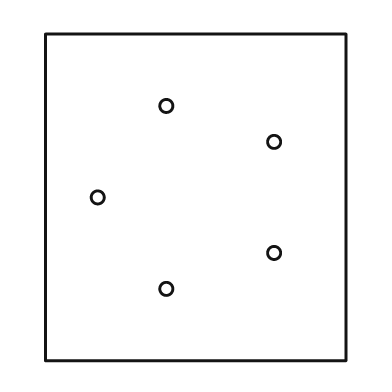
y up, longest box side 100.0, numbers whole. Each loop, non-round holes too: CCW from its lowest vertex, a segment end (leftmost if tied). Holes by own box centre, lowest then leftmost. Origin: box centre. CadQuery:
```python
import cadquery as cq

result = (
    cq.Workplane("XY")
    .moveTo(-46.0, -50.0)
    .lineTo(46.0, -50.0)
    .lineTo(46.0, 50.0)
    .lineTo(-46.0, 50.0)
    .close()
    .moveTo(-9.0, -28.0)
    .circle(2.0)
    .moveTo(24.0, -17.0)
    .circle(2.0)
    .moveTo(-30.0, 0.0)
    .circle(2.0)
    .moveTo(24.0, 17.0)
    .circle(2.0)
    .moveTo(-9.0, 28.0)
    .circle(2.0)
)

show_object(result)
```